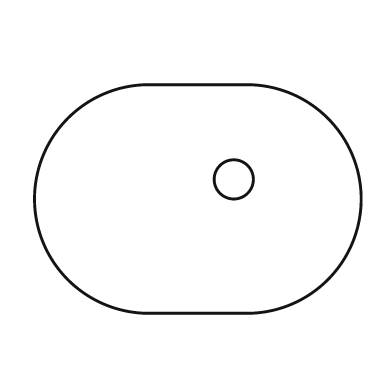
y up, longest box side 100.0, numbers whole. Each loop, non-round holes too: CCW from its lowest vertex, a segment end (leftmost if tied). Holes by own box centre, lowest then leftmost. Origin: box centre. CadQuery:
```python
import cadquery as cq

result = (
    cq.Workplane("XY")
    .moveTo(-15.0, -35.0)
    .lineTo(15.0, -35.0)
    .threePointArc((50.0, 0.0), (15.0, 35.0))
    .lineTo(-15.0, 35.0)
    .threePointArc((-50.0, 0.0), (-15.0, -35.0))
    .close()
    .moveTo(11.0, 6.0)
    .circle(6.0)
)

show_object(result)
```